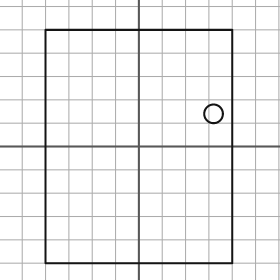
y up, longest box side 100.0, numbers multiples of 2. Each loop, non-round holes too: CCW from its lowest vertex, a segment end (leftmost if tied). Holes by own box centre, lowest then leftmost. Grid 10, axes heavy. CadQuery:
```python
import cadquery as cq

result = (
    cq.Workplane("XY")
    .moveTo(-40.0, -50.0)
    .lineTo(40.0, -50.0)
    .lineTo(40.0, 50.0)
    .lineTo(-40.0, 50.0)
    .close()
    .moveTo(32.0, 14.0)
    .circle(4.0)
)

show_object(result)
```